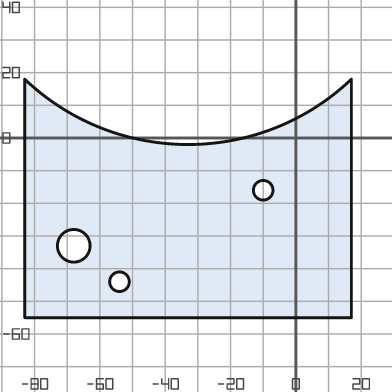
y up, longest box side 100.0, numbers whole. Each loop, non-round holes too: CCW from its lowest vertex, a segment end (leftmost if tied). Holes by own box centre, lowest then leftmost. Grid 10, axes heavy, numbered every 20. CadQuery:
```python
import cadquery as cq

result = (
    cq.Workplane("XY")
    .moveTo(-83.0, -55.0)
    .lineTo(17.0, -55.0)
    .lineTo(17.0, 18.0)
    .threePointArc((-33.0, -2.0), (-83.0, 18.0))
    .close()
    .moveTo(-54.0, -44.0)
    .circle(3.0)
    .moveTo(-68.0, -33.0)
    .circle(5.0)
    .moveTo(-10.0, -16.0)
    .circle(3.0)
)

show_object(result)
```